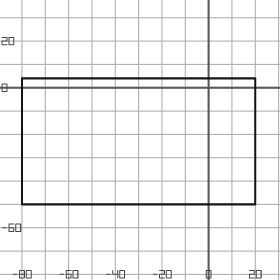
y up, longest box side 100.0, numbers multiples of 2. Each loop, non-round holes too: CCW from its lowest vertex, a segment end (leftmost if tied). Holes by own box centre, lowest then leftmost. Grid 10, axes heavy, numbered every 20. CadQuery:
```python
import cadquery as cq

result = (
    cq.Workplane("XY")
    .moveTo(-80.0, -50.0)
    .lineTo(20.0, -50.0)
    .lineTo(20.0, 4.0)
    .lineTo(-80.0, 4.0)
    .close()
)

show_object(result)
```